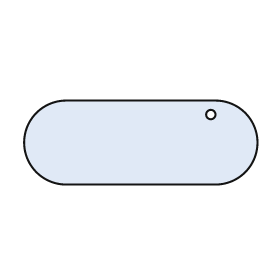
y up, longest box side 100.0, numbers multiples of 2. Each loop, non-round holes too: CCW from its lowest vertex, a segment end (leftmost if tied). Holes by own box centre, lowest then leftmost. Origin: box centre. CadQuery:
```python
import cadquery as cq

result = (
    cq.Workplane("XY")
    .moveTo(-32.0, -18.0)
    .lineTo(32.0, -18.0)
    .threePointArc((50.0, 0.0), (32.0, 18.0))
    .lineTo(-32.0, 18.0)
    .threePointArc((-50.0, 0.0), (-32.0, -18.0))
    .close()
    .moveTo(30.0, 12.0)
    .circle(2.0)
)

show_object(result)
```